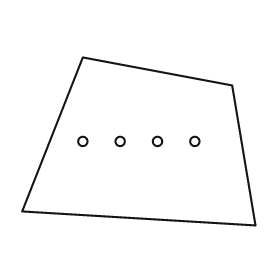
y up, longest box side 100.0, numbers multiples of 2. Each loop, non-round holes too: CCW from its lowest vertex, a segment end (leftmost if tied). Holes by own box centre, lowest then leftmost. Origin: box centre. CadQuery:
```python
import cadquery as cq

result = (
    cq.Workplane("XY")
    .moveTo(50.0, -36.0)
    .lineTo(40.0, 24.0)
    .lineTo(-24.0, 36.0)
    .lineTo(-50.0, -30.0)
    .close()
    .moveTo(-24.0, 0.0)
    .circle(2.0)
    .moveTo(-8.0, 0.0)
    .circle(2.0)
    .moveTo(8.0, 0.0)
    .circle(2.0)
    .moveTo(24.0, 0.0)
    .circle(2.0)
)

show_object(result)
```